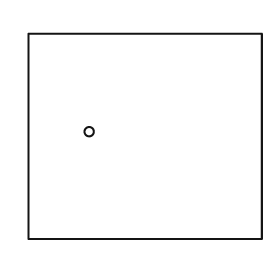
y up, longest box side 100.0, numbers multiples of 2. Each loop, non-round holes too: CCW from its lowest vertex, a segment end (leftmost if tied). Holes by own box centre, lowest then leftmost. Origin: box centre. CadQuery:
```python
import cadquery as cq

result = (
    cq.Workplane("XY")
    .moveTo(-50.0, -44.0)
    .lineTo(50.0, -44.0)
    .lineTo(50.0, 44.0)
    .lineTo(-50.0, 44.0)
    .close()
    .moveTo(-24.0, 2.0)
    .circle(2.0)
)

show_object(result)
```